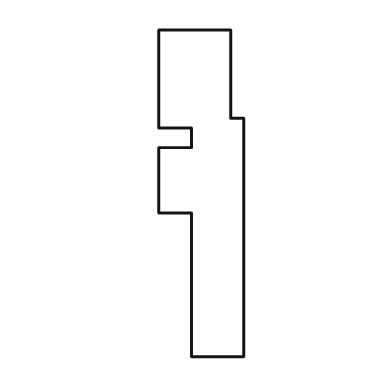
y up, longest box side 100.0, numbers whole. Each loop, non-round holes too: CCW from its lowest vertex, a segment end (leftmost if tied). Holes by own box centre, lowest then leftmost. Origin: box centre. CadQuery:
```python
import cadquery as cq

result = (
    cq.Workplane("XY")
    .moveTo(-3.0, -50.0)
    .lineTo(13.0, -50.0)
    .lineTo(13.0, 23.0)
    .lineTo(9.0, 23.0)
    .lineTo(9.0, 50.0)
    .lineTo(-13.0, 50.0)
    .lineTo(-13.0, 20.0)
    .lineTo(-3.0, 20.0)
    .lineTo(-3.0, 14.0)
    .lineTo(-13.0, 14.0)
    .lineTo(-13.0, -6.0)
    .lineTo(-3.0, -6.0)
    .close()
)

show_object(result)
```